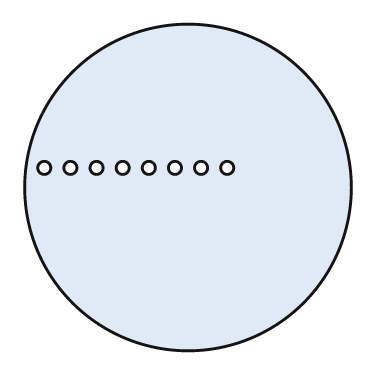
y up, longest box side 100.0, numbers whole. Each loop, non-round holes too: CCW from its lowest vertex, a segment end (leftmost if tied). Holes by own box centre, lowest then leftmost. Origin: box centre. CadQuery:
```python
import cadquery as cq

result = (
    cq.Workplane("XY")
    .moveTo(0.0, 0.0)
    .circle(50.0)
    .moveTo(-44.0, 6.0)
    .circle(2.0)
    .moveTo(-36.0, 6.0)
    .circle(2.0)
    .moveTo(-28.0, 6.0)
    .circle(2.0)
    .moveTo(-20.0, 6.0)
    .circle(2.0)
    .moveTo(-12.0, 6.0)
    .circle(2.0)
    .moveTo(-4.0, 6.0)
    .circle(2.0)
    .moveTo(4.0, 6.0)
    .circle(2.0)
    .moveTo(12.0, 6.0)
    .circle(2.0)
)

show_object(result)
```